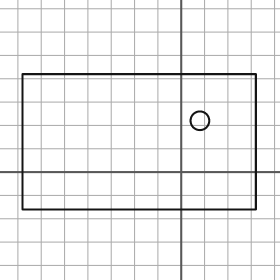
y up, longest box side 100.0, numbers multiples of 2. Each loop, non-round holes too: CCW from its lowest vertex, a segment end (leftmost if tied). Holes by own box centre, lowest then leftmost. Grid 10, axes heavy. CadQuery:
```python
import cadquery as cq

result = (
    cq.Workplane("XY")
    .moveTo(-68.0, -16.0)
    .lineTo(32.0, -16.0)
    .lineTo(32.0, 42.0)
    .lineTo(-68.0, 42.0)
    .close()
    .moveTo(8.0, 22.0)
    .circle(4.0)
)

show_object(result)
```